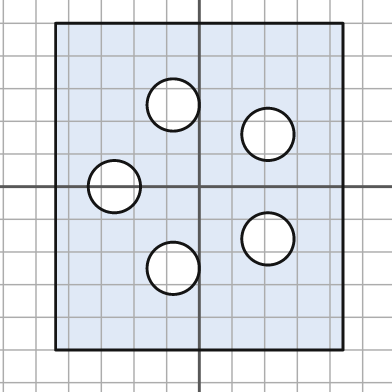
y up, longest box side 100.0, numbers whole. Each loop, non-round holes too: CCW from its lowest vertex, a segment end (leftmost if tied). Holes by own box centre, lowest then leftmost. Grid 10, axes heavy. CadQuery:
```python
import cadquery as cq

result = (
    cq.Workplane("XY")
    .moveTo(-44.0, -50.0)
    .lineTo(44.0, -50.0)
    .lineTo(44.0, 50.0)
    .lineTo(-44.0, 50.0)
    .close()
    .moveTo(-8.0, -25.0)
    .circle(8.0)
    .moveTo(21.0, -16.0)
    .circle(8.0)
    .moveTo(-26.0, 0.0)
    .circle(8.0)
    .moveTo(21.0, 16.0)
    .circle(8.0)
    .moveTo(-8.0, 25.0)
    .circle(8.0)
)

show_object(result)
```